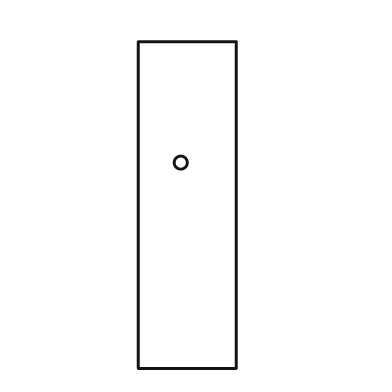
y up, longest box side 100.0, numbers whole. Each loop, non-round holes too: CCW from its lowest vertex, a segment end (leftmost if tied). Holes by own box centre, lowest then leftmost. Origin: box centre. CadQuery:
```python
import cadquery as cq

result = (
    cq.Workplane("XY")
    .moveTo(-15.0, -50.0)
    .lineTo(15.0, -50.0)
    .lineTo(15.0, 50.0)
    .lineTo(-15.0, 50.0)
    .close()
    .moveTo(-2.0, 13.0)
    .circle(2.0)
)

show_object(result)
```